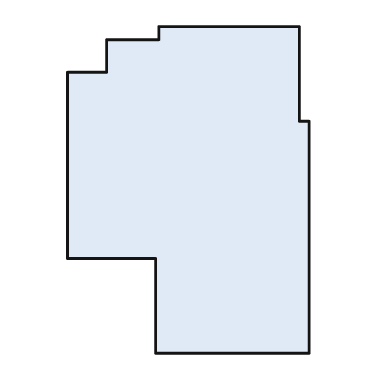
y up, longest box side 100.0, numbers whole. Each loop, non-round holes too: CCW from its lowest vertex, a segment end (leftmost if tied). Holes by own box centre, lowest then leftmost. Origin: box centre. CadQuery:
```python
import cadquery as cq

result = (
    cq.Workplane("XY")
    .moveTo(-10.0, -50.0)
    .lineTo(37.0, -50.0)
    .lineTo(37.0, 21.0)
    .lineTo(34.0, 21.0)
    .lineTo(34.0, 50.0)
    .lineTo(-9.0, 50.0)
    .lineTo(-9.0, 46.0)
    .lineTo(-25.0, 46.0)
    .lineTo(-25.0, 36.0)
    .lineTo(-37.0, 36.0)
    .lineTo(-37.0, -21.0)
    .lineTo(-10.0, -21.0)
    .close()
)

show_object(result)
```